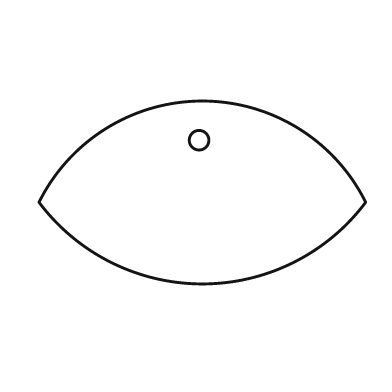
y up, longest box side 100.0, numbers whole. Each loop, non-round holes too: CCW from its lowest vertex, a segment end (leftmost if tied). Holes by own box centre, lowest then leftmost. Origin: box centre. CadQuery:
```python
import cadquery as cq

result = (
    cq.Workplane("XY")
    .moveTo(-50.0, -3.0)
    .threePointArc((0.0, -28.0), (50.0, -3.0))
    .threePointArc((0.0, 28.0), (-50.0, -3.0))
    .close()
    .moveTo(-1.0, 16.0)
    .circle(3.0)
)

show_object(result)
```